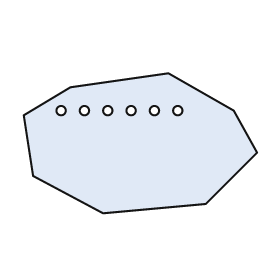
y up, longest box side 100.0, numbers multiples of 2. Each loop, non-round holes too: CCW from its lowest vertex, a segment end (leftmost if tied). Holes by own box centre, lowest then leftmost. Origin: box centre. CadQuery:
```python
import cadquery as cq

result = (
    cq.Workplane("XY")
    .moveTo(-16.0, -30.0)
    .lineTo(28.0, -26.0)
    .lineTo(50.0, -4.0)
    .lineTo(40.0, 14.0)
    .lineTo(12.0, 30.0)
    .lineTo(-30.0, 24.0)
    .lineTo(-50.0, 12.0)
    .lineTo(-46.0, -14.0)
    .close()
    .moveTo(-34.0, 14.0)
    .circle(2.0)
    .moveTo(-24.0, 14.0)
    .circle(2.0)
    .moveTo(-14.0, 14.0)
    .circle(2.0)
    .moveTo(-4.0, 14.0)
    .circle(2.0)
    .moveTo(6.0, 14.0)
    .circle(2.0)
    .moveTo(16.0, 14.0)
    .circle(2.0)
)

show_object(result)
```